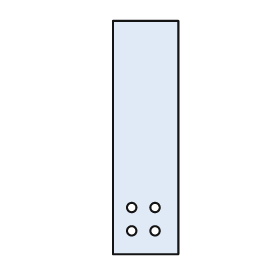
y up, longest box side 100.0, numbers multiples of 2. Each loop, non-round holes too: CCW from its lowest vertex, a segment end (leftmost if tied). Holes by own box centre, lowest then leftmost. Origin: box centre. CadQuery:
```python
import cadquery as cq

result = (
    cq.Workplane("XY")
    .moveTo(-14.0, -50.0)
    .lineTo(14.0, -50.0)
    .lineTo(14.0, 50.0)
    .lineTo(-14.0, 50.0)
    .close()
    .moveTo(-6.0, -40.0)
    .circle(2.0)
    .moveTo(4.0, -40.0)
    .circle(2.0)
    .moveTo(-6.0, -30.0)
    .circle(2.0)
    .moveTo(4.0, -30.0)
    .circle(2.0)
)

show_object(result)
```